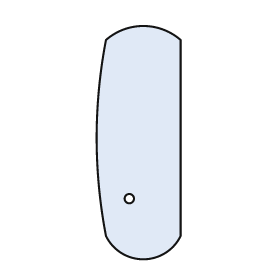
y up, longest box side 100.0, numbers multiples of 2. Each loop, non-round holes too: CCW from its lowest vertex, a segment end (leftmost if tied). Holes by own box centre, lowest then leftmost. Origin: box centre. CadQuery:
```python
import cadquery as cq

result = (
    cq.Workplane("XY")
    .moveTo(-14.0, -40.0)
    .threePointArc((2.0, -50.0), (18.0, -40.0))
    .lineTo(18.0, 44.0)
    .threePointArc((2.0, 50.0), (-14.0, 44.0))
    .threePointArc((-18.0, 2.0), (-14.0, -40.0))
    .close()
    .moveTo(-4.0, -24.0)
    .circle(2.0)
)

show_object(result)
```